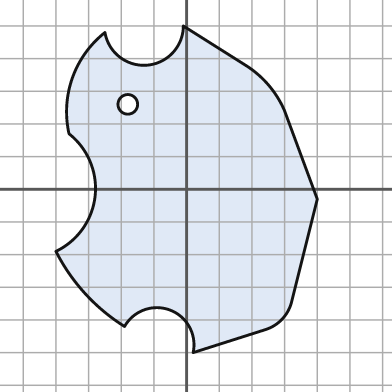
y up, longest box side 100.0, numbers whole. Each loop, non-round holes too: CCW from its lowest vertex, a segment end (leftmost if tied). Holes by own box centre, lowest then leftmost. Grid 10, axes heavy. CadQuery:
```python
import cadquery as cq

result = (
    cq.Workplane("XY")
    .moveTo(2.0, -50.0)
    .lineTo(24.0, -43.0)
    .threePointArc((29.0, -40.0), (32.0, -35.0))
    .lineTo(40.0, -3.0)
    .lineTo(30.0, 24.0)
    .threePointArc((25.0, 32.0), (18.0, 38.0))
    .lineTo(-1.0, 50.0)
    .threePointArc((-12.0, 38.0), (-25.0, 48.0))
    .threePointArc((-35.0, 34.0), (-36.0, 17.0))
    .threePointArc((-28.0, -2.0), (-40.0, -19.0))
    .threePointArc((-31.0, -32.0), (-19.0, -42.0))
    .threePointArc((-5.0, -37.0), (2.0, -50.0))
    .close()
    .moveTo(-18.0, 26.0)
    .circle(3.0)
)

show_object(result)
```